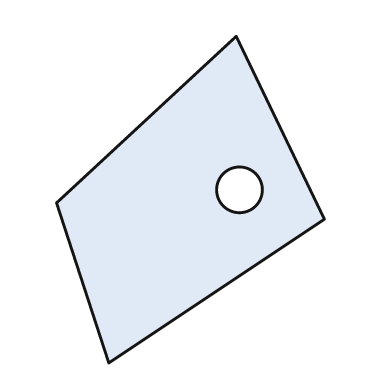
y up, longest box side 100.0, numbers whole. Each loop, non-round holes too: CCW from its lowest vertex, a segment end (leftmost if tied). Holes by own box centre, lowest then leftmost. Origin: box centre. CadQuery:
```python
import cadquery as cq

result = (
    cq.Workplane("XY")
    .moveTo(-25.0, -50.0)
    .lineTo(41.0, -6.0)
    .lineTo(14.0, 50.0)
    .lineTo(-41.0, -1.0)
    .close()
    .moveTo(15.0, 3.0)
    .circle(7.0)
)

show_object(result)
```